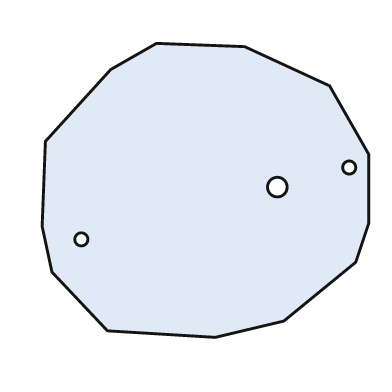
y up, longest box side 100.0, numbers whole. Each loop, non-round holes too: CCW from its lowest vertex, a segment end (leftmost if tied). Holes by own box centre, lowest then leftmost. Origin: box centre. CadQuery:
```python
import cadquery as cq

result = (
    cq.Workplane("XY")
    .moveTo(3.0, -45.0)
    .lineTo(24.0, -40.0)
    .lineTo(46.0, -22.0)
    .lineTo(50.0, -10.0)
    .lineTo(50.0, 11.0)
    .lineTo(38.0, 32.0)
    .lineTo(12.0, 44.0)
    .lineTo(-15.0, 45.0)
    .lineTo(-29.0, 37.0)
    .lineTo(-49.0, 15.0)
    .lineTo(-50.0, -11.0)
    .lineTo(-47.0, -25.0)
    .lineTo(-30.0, -43.0)
    .close()
    .moveTo(-38.0, -15.0)
    .circle(2.0)
    .moveTo(22.0, 1.0)
    .circle(3.0)
    .moveTo(44.0, 7.0)
    .circle(2.0)
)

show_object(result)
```